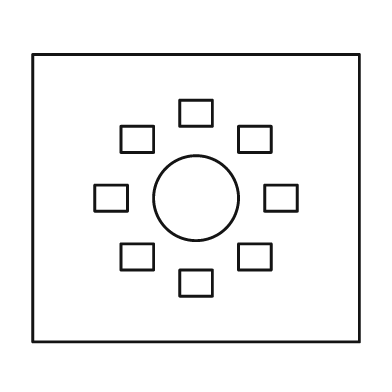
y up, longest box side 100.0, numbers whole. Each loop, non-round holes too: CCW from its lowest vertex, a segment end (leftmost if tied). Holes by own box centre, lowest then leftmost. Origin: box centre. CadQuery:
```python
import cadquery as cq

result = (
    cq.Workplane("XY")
    .moveTo(-50.0, -44.0)
    .lineTo(50.0, -44.0)
    .lineTo(50.0, 44.0)
    .lineTo(-50.0, 44.0)
    .close()
    .moveTo(-5.0, -30.0)
    .lineTo(5.0, -30.0)
    .lineTo(5.0, -22.0)
    .lineTo(-5.0, -22.0)
    .close()
    .moveTo(-23.0, -22.0)
    .lineTo(-13.0, -22.0)
    .lineTo(-13.0, -14.0)
    .lineTo(-23.0, -14.0)
    .close()
    .moveTo(13.0, -22.0)
    .lineTo(23.0, -22.0)
    .lineTo(23.0, -14.0)
    .lineTo(13.0, -14.0)
    .close()
    .moveTo(-31.0, -4.0)
    .lineTo(-21.0, -4.0)
    .lineTo(-21.0, 4.0)
    .lineTo(-31.0, 4.0)
    .close()
    .moveTo(0.0, 0.0)
    .circle(13.0)
    .moveTo(21.0, -4.0)
    .lineTo(31.0, -4.0)
    .lineTo(31.0, 4.0)
    .lineTo(21.0, 4.0)
    .close()
    .moveTo(-23.0, 14.0)
    .lineTo(-13.0, 14.0)
    .lineTo(-13.0, 22.0)
    .lineTo(-23.0, 22.0)
    .close()
    .moveTo(13.0, 14.0)
    .lineTo(23.0, 14.0)
    .lineTo(23.0, 22.0)
    .lineTo(13.0, 22.0)
    .close()
    .moveTo(-5.0, 22.0)
    .lineTo(5.0, 22.0)
    .lineTo(5.0, 30.0)
    .lineTo(-5.0, 30.0)
    .close()
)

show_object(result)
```